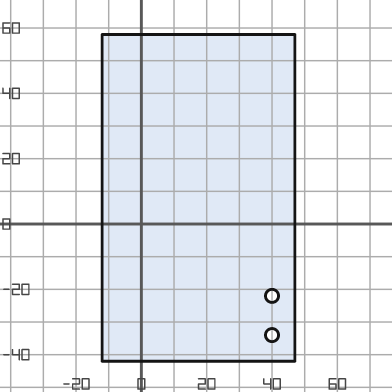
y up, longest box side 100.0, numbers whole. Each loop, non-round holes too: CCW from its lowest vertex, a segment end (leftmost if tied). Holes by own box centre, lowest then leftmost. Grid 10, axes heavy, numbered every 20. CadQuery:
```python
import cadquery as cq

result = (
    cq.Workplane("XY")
    .moveTo(-12.0, -42.0)
    .lineTo(47.0, -42.0)
    .lineTo(47.0, 58.0)
    .lineTo(-12.0, 58.0)
    .close()
    .moveTo(40.0, -34.0)
    .circle(2.0)
    .moveTo(40.0, -22.0)
    .circle(2.0)
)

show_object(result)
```